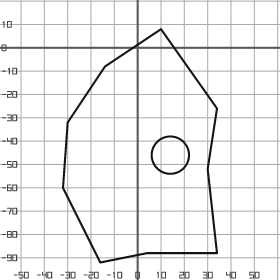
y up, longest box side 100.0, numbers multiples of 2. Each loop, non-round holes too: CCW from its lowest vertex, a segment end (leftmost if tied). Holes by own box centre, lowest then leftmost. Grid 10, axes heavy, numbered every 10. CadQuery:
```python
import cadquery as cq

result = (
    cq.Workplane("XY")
    .moveTo(-16.0, -92.0)
    .lineTo(4.0, -88.0)
    .lineTo(34.0, -88.0)
    .lineTo(30.0, -52.0)
    .lineTo(34.0, -26.0)
    .lineTo(10.0, 8.0)
    .lineTo(-14.0, -8.0)
    .lineTo(-30.0, -32.0)
    .lineTo(-32.0, -60.0)
    .close()
    .moveTo(14.0, -46.0)
    .circle(8.0)
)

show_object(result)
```